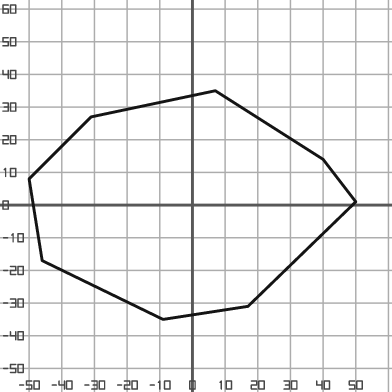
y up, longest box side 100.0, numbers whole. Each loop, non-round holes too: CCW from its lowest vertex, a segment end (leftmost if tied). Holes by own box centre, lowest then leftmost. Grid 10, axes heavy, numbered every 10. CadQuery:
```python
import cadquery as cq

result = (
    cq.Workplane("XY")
    .moveTo(-9.0, -35.0)
    .lineTo(17.0, -31.0)
    .lineTo(50.0, 1.0)
    .lineTo(40.0, 14.0)
    .lineTo(7.0, 35.0)
    .lineTo(-31.0, 27.0)
    .lineTo(-50.0, 8.0)
    .lineTo(-46.0, -17.0)
    .close()
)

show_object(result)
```